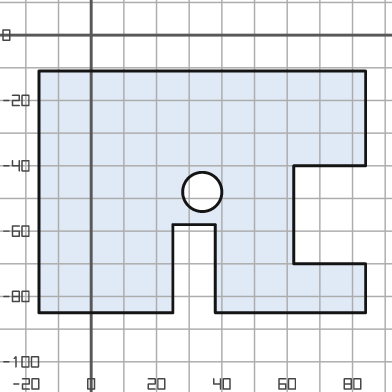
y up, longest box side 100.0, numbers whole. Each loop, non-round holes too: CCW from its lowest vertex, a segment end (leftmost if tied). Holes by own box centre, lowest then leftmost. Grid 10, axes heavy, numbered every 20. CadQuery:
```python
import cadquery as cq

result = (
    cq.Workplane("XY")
    .moveTo(-16.0, -85.0)
    .lineTo(25.0, -85.0)
    .lineTo(25.0, -58.0)
    .lineTo(38.0, -58.0)
    .lineTo(38.0, -85.0)
    .lineTo(84.0, -85.0)
    .lineTo(84.0, -70.0)
    .lineTo(62.0, -70.0)
    .lineTo(62.0, -40.0)
    .lineTo(84.0, -40.0)
    .lineTo(84.0, -11.0)
    .lineTo(-16.0, -11.0)
    .close()
    .moveTo(34.0, -48.0)
    .circle(6.0)
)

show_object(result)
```